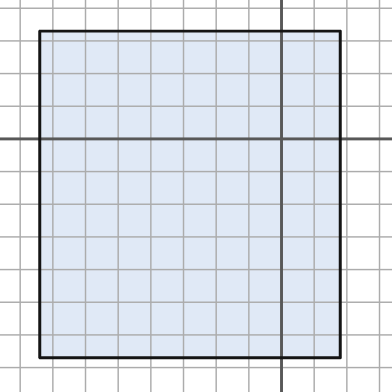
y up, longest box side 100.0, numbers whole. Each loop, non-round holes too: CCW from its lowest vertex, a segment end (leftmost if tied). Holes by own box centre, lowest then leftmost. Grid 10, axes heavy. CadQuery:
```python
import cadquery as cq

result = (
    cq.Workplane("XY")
    .moveTo(-74.0, -67.0)
    .lineTo(18.0, -67.0)
    .lineTo(18.0, 33.0)
    .lineTo(-74.0, 33.0)
    .close()
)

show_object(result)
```